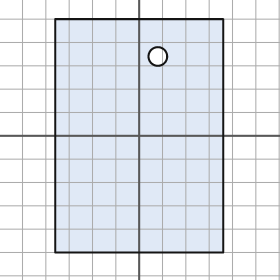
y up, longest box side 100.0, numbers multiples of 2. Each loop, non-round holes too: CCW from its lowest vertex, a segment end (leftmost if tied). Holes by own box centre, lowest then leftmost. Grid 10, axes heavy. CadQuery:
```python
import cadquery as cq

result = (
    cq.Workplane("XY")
    .moveTo(-36.0, -50.0)
    .lineTo(36.0, -50.0)
    .lineTo(36.0, 50.0)
    .lineTo(-36.0, 50.0)
    .close()
    .moveTo(8.0, 34.0)
    .circle(4.0)
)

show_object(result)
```